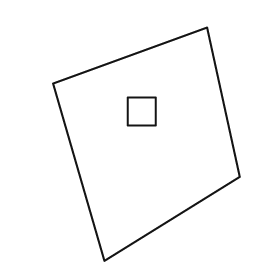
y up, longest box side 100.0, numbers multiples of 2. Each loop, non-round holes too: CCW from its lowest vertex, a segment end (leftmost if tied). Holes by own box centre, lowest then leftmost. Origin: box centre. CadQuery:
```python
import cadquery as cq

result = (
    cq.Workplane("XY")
    .moveTo(-18.0, -50.0)
    .lineTo(40.0, -14.0)
    .lineTo(26.0, 50.0)
    .lineTo(-40.0, 26.0)
    .close()
    .moveTo(-8.0, 8.0)
    .lineTo(4.0, 8.0)
    .lineTo(4.0, 20.0)
    .lineTo(-8.0, 20.0)
    .close()
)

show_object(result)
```